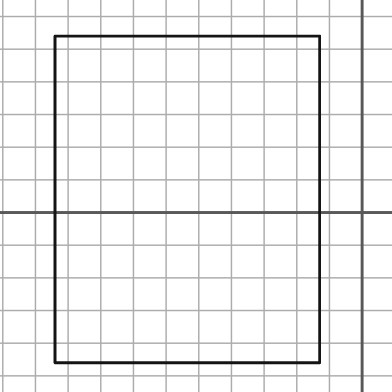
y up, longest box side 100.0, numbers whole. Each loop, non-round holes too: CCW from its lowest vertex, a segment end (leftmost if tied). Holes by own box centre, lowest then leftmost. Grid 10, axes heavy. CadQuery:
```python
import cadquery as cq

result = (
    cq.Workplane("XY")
    .moveTo(-94.0, -46.0)
    .lineTo(-13.0, -46.0)
    .lineTo(-13.0, 54.0)
    .lineTo(-94.0, 54.0)
    .close()
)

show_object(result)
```